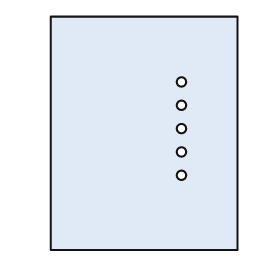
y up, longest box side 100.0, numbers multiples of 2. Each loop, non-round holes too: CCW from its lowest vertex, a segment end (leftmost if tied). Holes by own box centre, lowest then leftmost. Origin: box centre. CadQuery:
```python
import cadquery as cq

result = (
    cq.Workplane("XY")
    .moveTo(-40.0, -50.0)
    .lineTo(40.0, -50.0)
    .lineTo(40.0, 50.0)
    .lineTo(-40.0, 50.0)
    .close()
    .moveTo(16.0, -18.0)
    .circle(2.0)
    .moveTo(16.0, -8.0)
    .circle(2.0)
    .moveTo(16.0, 2.0)
    .circle(2.0)
    .moveTo(16.0, 12.0)
    .circle(2.0)
    .moveTo(16.0, 22.0)
    .circle(2.0)
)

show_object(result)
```